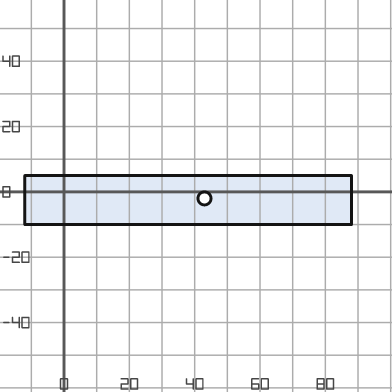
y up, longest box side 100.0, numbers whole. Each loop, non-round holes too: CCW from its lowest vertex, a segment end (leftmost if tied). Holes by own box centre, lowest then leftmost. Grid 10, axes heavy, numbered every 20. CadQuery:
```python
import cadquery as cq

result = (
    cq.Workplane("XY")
    .moveTo(-12.0, -10.0)
    .lineTo(88.0, -10.0)
    .lineTo(88.0, 5.0)
    .lineTo(-12.0, 5.0)
    .close()
    .moveTo(43.0, -2.0)
    .circle(2.0)
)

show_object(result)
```